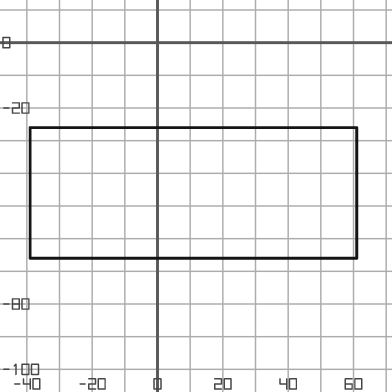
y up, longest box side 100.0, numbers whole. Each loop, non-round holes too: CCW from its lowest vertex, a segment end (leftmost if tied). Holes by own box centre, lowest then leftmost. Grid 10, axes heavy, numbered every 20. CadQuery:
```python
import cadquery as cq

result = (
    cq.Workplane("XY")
    .moveTo(-39.0, -66.0)
    .lineTo(61.0, -66.0)
    .lineTo(61.0, -26.0)
    .lineTo(-39.0, -26.0)
    .close()
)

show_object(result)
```